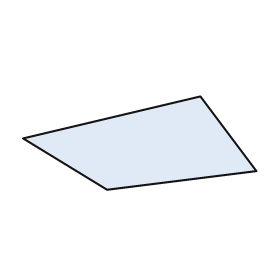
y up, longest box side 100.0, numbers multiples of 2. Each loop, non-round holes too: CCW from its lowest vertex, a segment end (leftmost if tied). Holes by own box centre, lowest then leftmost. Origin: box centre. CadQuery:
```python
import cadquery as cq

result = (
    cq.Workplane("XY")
    .moveTo(-14.0, -20.0)
    .lineTo(50.0, -12.0)
    .lineTo(26.0, 20.0)
    .lineTo(-50.0, 2.0)
    .close()
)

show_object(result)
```